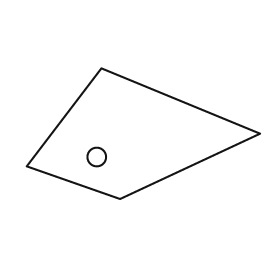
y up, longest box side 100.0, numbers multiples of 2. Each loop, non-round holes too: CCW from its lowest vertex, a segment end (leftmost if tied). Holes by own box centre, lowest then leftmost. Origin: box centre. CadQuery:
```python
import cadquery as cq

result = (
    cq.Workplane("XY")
    .moveTo(-10.0, -28.0)
    .lineTo(50.0, 0.0)
    .lineTo(-18.0, 28.0)
    .lineTo(-50.0, -14.0)
    .close()
    .moveTo(-20.0, -10.0)
    .circle(4.0)
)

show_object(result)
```